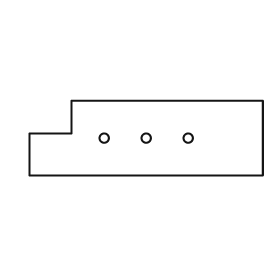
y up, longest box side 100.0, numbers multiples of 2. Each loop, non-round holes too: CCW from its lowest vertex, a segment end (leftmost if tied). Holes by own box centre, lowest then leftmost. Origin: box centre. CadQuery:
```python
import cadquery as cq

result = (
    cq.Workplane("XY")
    .moveTo(-50.0, -16.0)
    .lineTo(50.0, -16.0)
    .lineTo(50.0, 16.0)
    .lineTo(-32.0, 16.0)
    .lineTo(-32.0, 2.0)
    .lineTo(-50.0, 2.0)
    .close()
    .moveTo(-18.0, 0.0)
    .circle(2.0)
    .moveTo(0.0, 0.0)
    .circle(2.0)
    .moveTo(18.0, 0.0)
    .circle(2.0)
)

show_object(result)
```